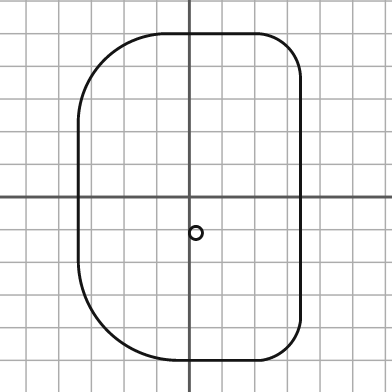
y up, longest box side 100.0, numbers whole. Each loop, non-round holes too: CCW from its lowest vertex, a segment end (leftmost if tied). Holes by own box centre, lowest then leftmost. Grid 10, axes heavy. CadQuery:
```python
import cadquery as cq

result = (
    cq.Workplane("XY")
    .moveTo(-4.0, -50.0)
    .lineTo(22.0, -50.0)
    .threePointArc((30.0, -46.0), (34.0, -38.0))
    .lineTo(34.0, 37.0)
    .threePointArc((30.0, 46.0), (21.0, 50.0))
    .lineTo(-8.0, 50.0)
    .threePointArc((-26.0, 42.0), (-34.0, 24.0))
    .lineTo(-34.0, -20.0)
    .threePointArc((-25.0, -41.0), (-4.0, -50.0))
    .close()
    .moveTo(2.0, -11.0)
    .circle(2.0)
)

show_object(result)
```